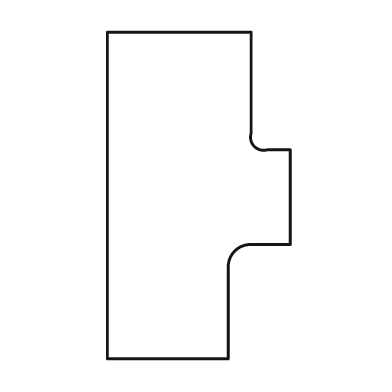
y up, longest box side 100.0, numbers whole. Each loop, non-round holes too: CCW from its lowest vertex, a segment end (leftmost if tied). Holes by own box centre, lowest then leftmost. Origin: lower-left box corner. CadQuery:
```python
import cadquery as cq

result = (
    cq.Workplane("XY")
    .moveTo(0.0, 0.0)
    .lineTo(37.0, 0.0)
    .lineTo(37.0, 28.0)
    .threePointArc((39.0, 33.0), (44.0, 35.0))
    .lineTo(56.0, 35.0)
    .lineTo(56.0, 64.0)
    .lineTo(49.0, 64.0)
    .threePointArc((45.0, 65.0), (44.0, 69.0))
    .lineTo(44.0, 100.0)
    .lineTo(0.0, 100.0)
    .close()
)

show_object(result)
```